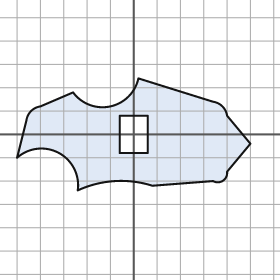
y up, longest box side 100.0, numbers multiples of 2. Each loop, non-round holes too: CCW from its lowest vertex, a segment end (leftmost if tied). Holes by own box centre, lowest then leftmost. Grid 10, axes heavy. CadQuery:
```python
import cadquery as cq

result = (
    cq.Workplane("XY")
    .moveTo(-24.0, -24.0)
    .threePointArc((-8.0, -20.0), (8.0, -22.0))
    .lineTo(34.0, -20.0)
    .threePointArc((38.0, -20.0), (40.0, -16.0))
    .lineTo(50.0, -4.0)
    .lineTo(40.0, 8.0)
    .threePointArc((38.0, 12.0), (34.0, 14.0))
    .lineTo(2.0, 24.0)
    .threePointArc((-10.0, 12.0), (-26.0, 18.0))
    .lineTo(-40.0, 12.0)
    .threePointArc((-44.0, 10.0), (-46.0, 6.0))
    .lineTo(-50.0, -10.0)
    .threePointArc((-32.0, -8.0), (-24.0, -24.0))
    .close()
    .moveTo(-6.0, -8.0)
    .lineTo(6.0, -8.0)
    .lineTo(6.0, 8.0)
    .lineTo(-6.0, 8.0)
    .close()
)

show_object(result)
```